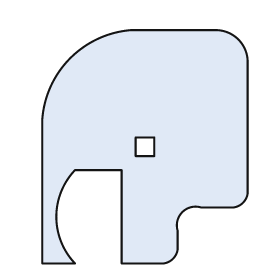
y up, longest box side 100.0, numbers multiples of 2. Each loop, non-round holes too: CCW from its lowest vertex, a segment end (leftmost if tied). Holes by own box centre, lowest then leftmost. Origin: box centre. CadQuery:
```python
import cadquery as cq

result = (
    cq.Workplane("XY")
    .moveTo(-44.0, -50.0)
    .lineTo(-30.0, -50.0)
    .threePointArc((-38.0, -30.0), (-30.0, -10.0))
    .lineTo(-10.0, -10.0)
    .lineTo(-10.0, -50.0)
    .lineTo(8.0, -50.0)
    .threePointArc((12.0, -48.0), (14.0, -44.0))
    .lineTo(14.0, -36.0)
    .threePointArc((16.0, -28.0), (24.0, -26.0))
    .lineTo(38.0, -26.0)
    .threePointArc((42.0, -24.0), (44.0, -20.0))
    .lineTo(44.0, 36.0)
    .threePointArc((40.0, 46.0), (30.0, 50.0))
    .lineTo(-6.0, 50.0)
    .threePointArc((-32.0, 38.0), (-44.0, 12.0))
    .close()
    .moveTo(-4.0, -4.0)
    .lineTo(4.0, -4.0)
    .lineTo(4.0, 4.0)
    .lineTo(-4.0, 4.0)
    .close()
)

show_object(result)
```